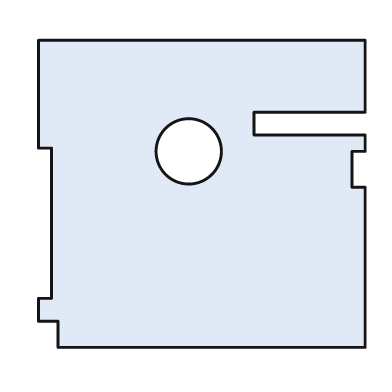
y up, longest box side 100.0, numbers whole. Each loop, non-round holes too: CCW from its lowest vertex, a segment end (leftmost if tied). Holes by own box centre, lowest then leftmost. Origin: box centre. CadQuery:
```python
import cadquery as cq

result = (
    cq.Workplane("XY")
    .moveTo(-44.0, -47.0)
    .lineTo(50.0, -47.0)
    .lineTo(50.0, 2.0)
    .lineTo(46.0, 2.0)
    .lineTo(46.0, 13.0)
    .lineTo(50.0, 13.0)
    .lineTo(50.0, 18.0)
    .lineTo(16.0, 18.0)
    .lineTo(16.0, 25.0)
    .lineTo(50.0, 25.0)
    .lineTo(50.0, 47.0)
    .lineTo(-50.0, 47.0)
    .lineTo(-50.0, 14.0)
    .lineTo(-46.0, 14.0)
    .lineTo(-46.0, -32.0)
    .lineTo(-50.0, -32.0)
    .lineTo(-50.0, -39.0)
    .lineTo(-44.0, -39.0)
    .close()
    .moveTo(-4.0, 13.0)
    .circle(10.0)
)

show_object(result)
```